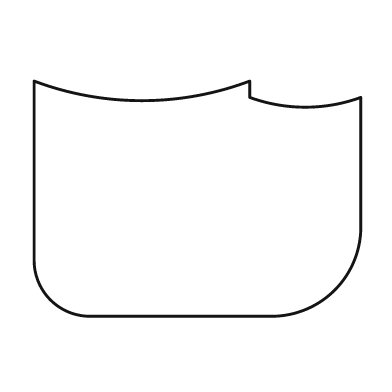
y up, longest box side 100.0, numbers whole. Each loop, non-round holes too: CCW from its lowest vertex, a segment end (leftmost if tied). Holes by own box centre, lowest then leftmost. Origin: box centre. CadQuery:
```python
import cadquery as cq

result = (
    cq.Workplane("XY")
    .moveTo(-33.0, -36.0)
    .lineTo(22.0, -36.0)
    .threePointArc((42.0, -28.0), (50.0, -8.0))
    .lineTo(50.0, 31.0)
    .threePointArc((33.0, 28.0), (16.0, 31.0))
    .lineTo(16.0, 36.0)
    .threePointArc((-17.0, 30.0), (-50.0, 36.0))
    .lineTo(-50.0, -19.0)
    .threePointArc((-45.0, -31.0), (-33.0, -36.0))
    .close()
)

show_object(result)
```